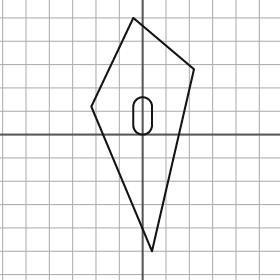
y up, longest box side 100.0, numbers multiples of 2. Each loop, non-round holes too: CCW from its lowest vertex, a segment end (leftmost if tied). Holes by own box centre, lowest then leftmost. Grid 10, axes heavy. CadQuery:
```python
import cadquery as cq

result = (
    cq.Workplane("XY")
    .moveTo(4.0, -50.0)
    .lineTo(22.0, 28.0)
    .lineTo(-4.0, 50.0)
    .lineTo(-22.0, 12.0)
    .close()
    .moveTo(-4.0, 4.0)
    .threePointArc((0.0, 0.0), (4.0, 4.0))
    .lineTo(4.0, 12.0)
    .threePointArc((0.0, 16.0), (-4.0, 12.0))
    .close()
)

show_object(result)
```